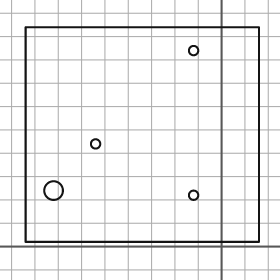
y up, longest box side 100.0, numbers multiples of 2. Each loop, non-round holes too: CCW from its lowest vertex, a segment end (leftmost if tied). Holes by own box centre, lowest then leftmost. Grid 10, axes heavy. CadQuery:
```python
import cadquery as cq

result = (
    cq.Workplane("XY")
    .moveTo(-84.0, 2.0)
    .lineTo(16.0, 2.0)
    .lineTo(16.0, 94.0)
    .lineTo(-84.0, 94.0)
    .close()
    .moveTo(-12.0, 22.0)
    .circle(2.0)
    .moveTo(-72.0, 24.0)
    .circle(4.0)
    .moveTo(-54.0, 44.0)
    .circle(2.0)
    .moveTo(-12.0, 84.0)
    .circle(2.0)
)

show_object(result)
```